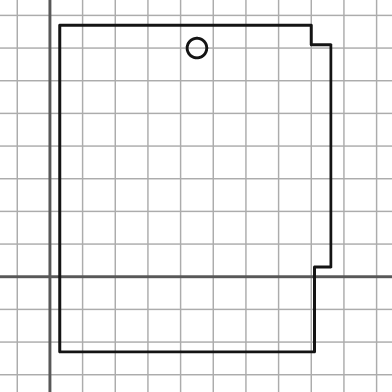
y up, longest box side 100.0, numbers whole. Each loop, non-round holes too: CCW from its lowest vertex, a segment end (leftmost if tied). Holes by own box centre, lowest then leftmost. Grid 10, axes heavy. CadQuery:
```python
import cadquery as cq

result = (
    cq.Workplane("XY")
    .moveTo(3.0, -23.0)
    .lineTo(81.0, -23.0)
    .lineTo(81.0, 3.0)
    .lineTo(86.0, 3.0)
    .lineTo(86.0, 71.0)
    .lineTo(80.0, 71.0)
    .lineTo(80.0, 77.0)
    .lineTo(3.0, 77.0)
    .close()
    .moveTo(45.0, 70.0)
    .circle(3.0)
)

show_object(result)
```